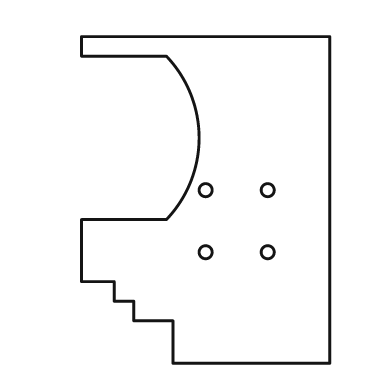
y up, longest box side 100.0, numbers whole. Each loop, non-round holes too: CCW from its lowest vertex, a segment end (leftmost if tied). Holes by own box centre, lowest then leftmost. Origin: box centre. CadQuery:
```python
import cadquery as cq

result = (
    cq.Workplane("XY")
    .moveTo(-10.0, -50.0)
    .lineTo(38.0, -50.0)
    .lineTo(38.0, 50.0)
    .lineTo(-38.0, 50.0)
    .lineTo(-38.0, 44.0)
    .lineTo(-12.0, 44.0)
    .threePointArc((-2.0, 19.0), (-12.0, -6.0))
    .lineTo(-38.0, -6.0)
    .lineTo(-38.0, -25.0)
    .lineTo(-28.0, -25.0)
    .lineTo(-28.0, -31.0)
    .lineTo(-22.0, -31.0)
    .lineTo(-22.0, -37.0)
    .lineTo(-10.0, -37.0)
    .close()
    .moveTo(0.0, -16.0)
    .circle(2.0)
    .moveTo(19.0, -16.0)
    .circle(2.0)
    .moveTo(0.0, 3.0)
    .circle(2.0)
    .moveTo(19.0, 3.0)
    .circle(2.0)
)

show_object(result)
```